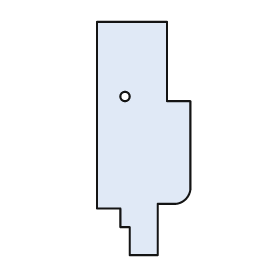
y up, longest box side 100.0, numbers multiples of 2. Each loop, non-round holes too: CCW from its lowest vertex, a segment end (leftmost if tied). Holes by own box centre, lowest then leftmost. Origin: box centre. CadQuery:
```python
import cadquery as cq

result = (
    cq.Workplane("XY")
    .moveTo(-6.0, -50.0)
    .lineTo(6.0, -50.0)
    .lineTo(6.0, -28.0)
    .lineTo(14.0, -28.0)
    .threePointArc((18.0, -26.0), (20.0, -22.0))
    .lineTo(20.0, 16.0)
    .lineTo(10.0, 16.0)
    .lineTo(10.0, 50.0)
    .lineTo(-20.0, 50.0)
    .lineTo(-20.0, -30.0)
    .lineTo(-10.0, -30.0)
    .lineTo(-10.0, -38.0)
    .lineTo(-6.0, -38.0)
    .close()
    .moveTo(-8.0, 18.0)
    .circle(2.0)
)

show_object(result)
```